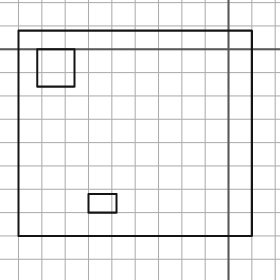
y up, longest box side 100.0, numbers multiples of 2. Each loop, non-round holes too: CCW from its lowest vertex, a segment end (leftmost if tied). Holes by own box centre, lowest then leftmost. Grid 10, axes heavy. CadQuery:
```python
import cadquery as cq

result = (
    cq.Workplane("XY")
    .moveTo(-90.0, -80.0)
    .lineTo(10.0, -80.0)
    .lineTo(10.0, 8.0)
    .lineTo(-90.0, 8.0)
    .close()
    .moveTo(-60.0, -70.0)
    .lineTo(-48.0, -70.0)
    .lineTo(-48.0, -62.0)
    .lineTo(-60.0, -62.0)
    .close()
    .moveTo(-82.0, -16.0)
    .lineTo(-66.0, -16.0)
    .lineTo(-66.0, 0.0)
    .lineTo(-82.0, 0.0)
    .close()
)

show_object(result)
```